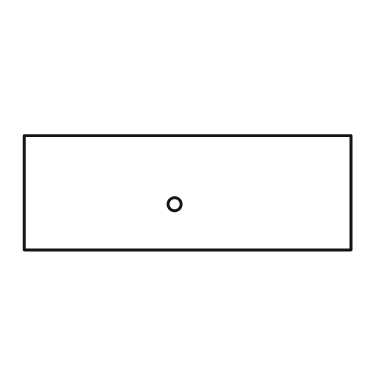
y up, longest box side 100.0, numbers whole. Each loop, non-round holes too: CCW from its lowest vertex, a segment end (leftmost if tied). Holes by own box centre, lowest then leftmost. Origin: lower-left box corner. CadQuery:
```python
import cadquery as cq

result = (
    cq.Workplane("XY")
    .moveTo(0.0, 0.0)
    .lineTo(100.0, 0.0)
    .lineTo(100.0, 35.0)
    .lineTo(0.0, 35.0)
    .close()
    .moveTo(46.0, 14.0)
    .circle(2.0)
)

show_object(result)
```